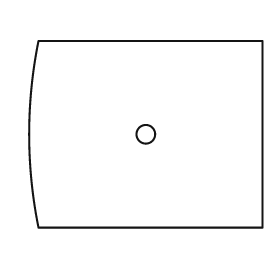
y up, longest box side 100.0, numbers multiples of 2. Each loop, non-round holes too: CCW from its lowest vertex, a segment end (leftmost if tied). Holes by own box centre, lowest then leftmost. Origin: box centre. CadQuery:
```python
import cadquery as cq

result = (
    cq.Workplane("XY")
    .moveTo(-46.0, -40.0)
    .lineTo(50.0, -40.0)
    .lineTo(50.0, 40.0)
    .lineTo(-46.0, 40.0)
    .threePointArc((-50.0, 0.0), (-46.0, -40.0))
    .close()
    .moveTo(0.0, 0.0)
    .circle(4.0)
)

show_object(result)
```